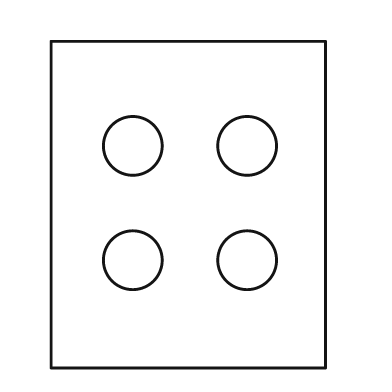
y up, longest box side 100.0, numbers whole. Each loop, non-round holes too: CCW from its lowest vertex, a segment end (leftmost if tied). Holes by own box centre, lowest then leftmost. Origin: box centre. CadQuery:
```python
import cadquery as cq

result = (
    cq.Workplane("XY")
    .moveTo(-42.0, -50.0)
    .lineTo(42.0, -50.0)
    .lineTo(42.0, 50.0)
    .lineTo(-42.0, 50.0)
    .close()
    .moveTo(-17.0, -17.0)
    .circle(9.0)
    .moveTo(18.0, -17.0)
    .circle(9.0)
    .moveTo(-17.0, 18.0)
    .circle(9.0)
    .moveTo(18.0, 18.0)
    .circle(9.0)
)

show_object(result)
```